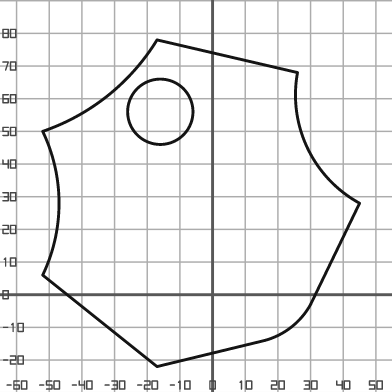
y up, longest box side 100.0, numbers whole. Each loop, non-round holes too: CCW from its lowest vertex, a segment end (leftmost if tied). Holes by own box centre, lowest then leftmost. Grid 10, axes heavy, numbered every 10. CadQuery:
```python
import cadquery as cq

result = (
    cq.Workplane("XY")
    .moveTo(-17.0, -22.0)
    .lineTo(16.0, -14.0)
    .threePointArc((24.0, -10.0), (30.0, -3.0))
    .lineTo(45.0, 28.0)
    .threePointArc((29.0, 45.0), (26.0, 68.0))
    .lineTo(-17.0, 78.0)
    .threePointArc((-32.0, 61.0), (-52.0, 50.0))
    .threePointArc((-47.0, 28.0), (-52.0, 6.0))
    .close()
    .moveTo(-16.0, 56.0)
    .circle(10.0)
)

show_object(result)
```